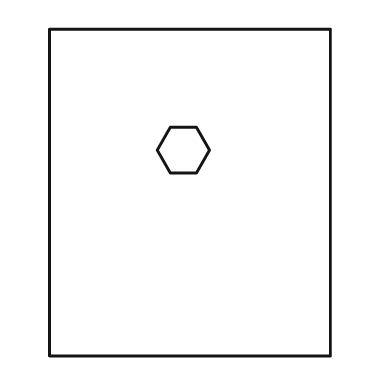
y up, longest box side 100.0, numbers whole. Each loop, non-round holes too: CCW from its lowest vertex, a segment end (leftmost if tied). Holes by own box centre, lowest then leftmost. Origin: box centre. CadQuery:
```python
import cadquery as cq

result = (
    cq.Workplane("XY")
    .moveTo(-43.0, -50.0)
    .lineTo(43.0, -50.0)
    .lineTo(43.0, 50.0)
    .lineTo(-43.0, 50.0)
    .close()
    .moveTo(-6.0, 6.0)
    .lineTo(2.0, 6.0)
    .lineTo(6.0, 13.0)
    .lineTo(2.0, 20.0)
    .lineTo(-6.0, 20.0)
    .lineTo(-10.0, 13.0)
    .close()
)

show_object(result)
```